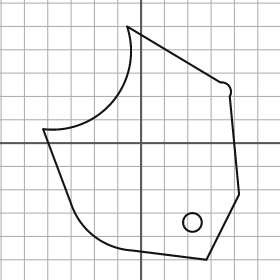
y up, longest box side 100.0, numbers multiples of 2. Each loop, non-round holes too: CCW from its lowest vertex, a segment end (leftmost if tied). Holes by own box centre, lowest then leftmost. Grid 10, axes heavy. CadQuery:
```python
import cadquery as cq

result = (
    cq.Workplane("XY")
    .moveTo(28.0, -50.0)
    .lineTo(42.0, -22.0)
    .lineTo(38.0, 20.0)
    .threePointArc((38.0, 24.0), (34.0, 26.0))
    .lineTo(-6.0, 50.0)
    .threePointArc((-12.0, 18.0), (-42.0, 6.0))
    .lineTo(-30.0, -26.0)
    .threePointArc((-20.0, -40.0), (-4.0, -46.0))
    .close()
    .moveTo(22.0, -34.0)
    .circle(4.0)
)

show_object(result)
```